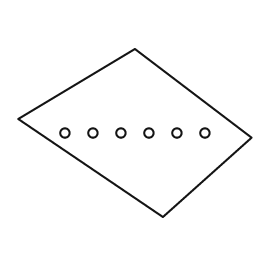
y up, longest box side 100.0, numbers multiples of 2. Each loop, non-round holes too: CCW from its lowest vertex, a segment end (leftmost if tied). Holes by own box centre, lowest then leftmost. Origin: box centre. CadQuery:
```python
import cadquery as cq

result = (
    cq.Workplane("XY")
    .moveTo(12.0, -36.0)
    .lineTo(50.0, -2.0)
    .lineTo(0.0, 36.0)
    .lineTo(-50.0, 6.0)
    .close()
    .moveTo(-30.0, 0.0)
    .circle(2.0)
    .moveTo(-18.0, 0.0)
    .circle(2.0)
    .moveTo(-6.0, 0.0)
    .circle(2.0)
    .moveTo(6.0, 0.0)
    .circle(2.0)
    .moveTo(18.0, 0.0)
    .circle(2.0)
    .moveTo(30.0, 0.0)
    .circle(2.0)
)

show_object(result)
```